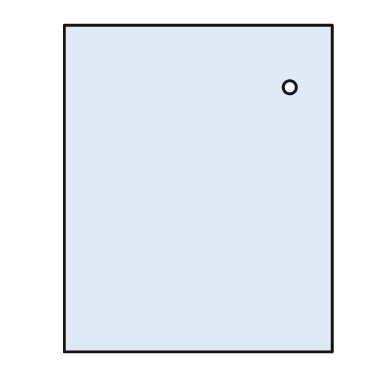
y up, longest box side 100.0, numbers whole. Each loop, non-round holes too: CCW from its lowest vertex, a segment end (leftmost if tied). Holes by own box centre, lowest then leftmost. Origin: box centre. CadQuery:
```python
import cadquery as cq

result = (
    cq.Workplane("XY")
    .moveTo(-41.0, -50.0)
    .lineTo(41.0, -50.0)
    .lineTo(41.0, 50.0)
    .lineTo(-41.0, 50.0)
    .close()
    .moveTo(28.0, 31.0)
    .circle(2.0)
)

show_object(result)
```